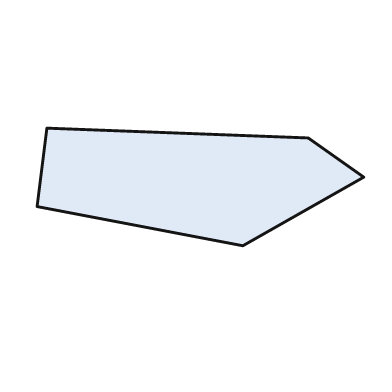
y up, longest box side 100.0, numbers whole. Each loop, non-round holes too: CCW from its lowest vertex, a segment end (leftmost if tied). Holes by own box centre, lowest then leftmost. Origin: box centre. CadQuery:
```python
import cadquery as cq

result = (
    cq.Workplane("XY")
    .moveTo(13.0, -18.0)
    .lineTo(50.0, 3.0)
    .lineTo(33.0, 15.0)
    .lineTo(-47.0, 18.0)
    .lineTo(-50.0, -6.0)
    .close()
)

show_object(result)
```